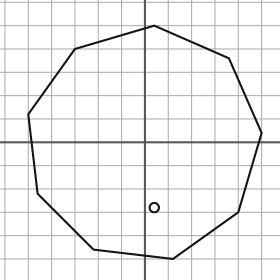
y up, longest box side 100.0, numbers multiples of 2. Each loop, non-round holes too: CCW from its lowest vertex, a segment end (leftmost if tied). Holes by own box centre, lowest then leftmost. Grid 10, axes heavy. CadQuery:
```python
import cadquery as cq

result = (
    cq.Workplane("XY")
    .moveTo(12.0, -50.0)
    .lineTo(40.0, -30.0)
    .lineTo(50.0, 4.0)
    .lineTo(36.0, 36.0)
    .lineTo(4.0, 50.0)
    .lineTo(-30.0, 40.0)
    .lineTo(-50.0, 12.0)
    .lineTo(-46.0, -22.0)
    .lineTo(-22.0, -46.0)
    .close()
    .moveTo(4.0, -28.0)
    .circle(2.0)
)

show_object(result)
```